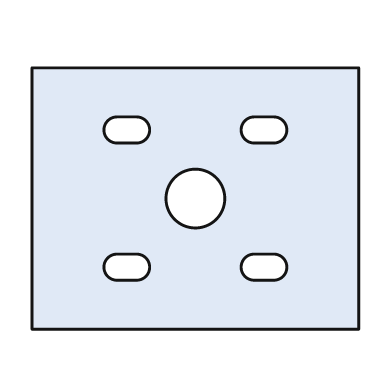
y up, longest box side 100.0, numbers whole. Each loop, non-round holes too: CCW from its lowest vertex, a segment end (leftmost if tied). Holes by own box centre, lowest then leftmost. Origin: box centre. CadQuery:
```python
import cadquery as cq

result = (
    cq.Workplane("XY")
    .moveTo(-50.0, -40.0)
    .lineTo(50.0, -40.0)
    .lineTo(50.0, 40.0)
    .lineTo(-50.0, 40.0)
    .close()
    .moveTo(-24.0, -25.0)
    .lineTo(-18.0, -25.0)
    .threePointArc((-14.0, -21.0), (-18.0, -17.0))
    .lineTo(-24.0, -17.0)
    .threePointArc((-28.0, -21.0), (-24.0, -25.0))
    .close()
    .moveTo(18.0, -25.0)
    .lineTo(24.0, -25.0)
    .threePointArc((28.0, -21.0), (24.0, -17.0))
    .lineTo(18.0, -17.0)
    .threePointArc((14.0, -21.0), (18.0, -25.0))
    .close()
    .moveTo(0.0, 0.0)
    .circle(9.0)
    .moveTo(-24.0, 17.0)
    .lineTo(-18.0, 17.0)
    .threePointArc((-14.0, 21.0), (-18.0, 25.0))
    .lineTo(-24.0, 25.0)
    .threePointArc((-28.0, 21.0), (-24.0, 17.0))
    .close()
    .moveTo(18.0, 17.0)
    .lineTo(24.0, 17.0)
    .threePointArc((28.0, 21.0), (24.0, 25.0))
    .lineTo(18.0, 25.0)
    .threePointArc((14.0, 21.0), (18.0, 17.0))
    .close()
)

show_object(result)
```